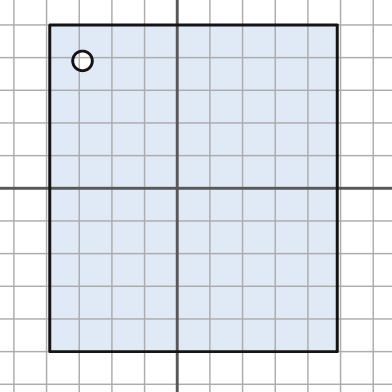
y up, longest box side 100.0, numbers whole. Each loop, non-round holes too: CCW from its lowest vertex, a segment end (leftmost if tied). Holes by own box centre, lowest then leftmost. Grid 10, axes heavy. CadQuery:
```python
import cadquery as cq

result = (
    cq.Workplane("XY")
    .moveTo(-39.0, -50.0)
    .lineTo(49.0, -50.0)
    .lineTo(49.0, 50.0)
    .lineTo(-39.0, 50.0)
    .close()
    .moveTo(-29.0, 39.0)
    .circle(3.0)
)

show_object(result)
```